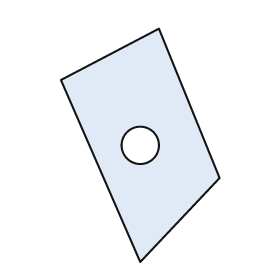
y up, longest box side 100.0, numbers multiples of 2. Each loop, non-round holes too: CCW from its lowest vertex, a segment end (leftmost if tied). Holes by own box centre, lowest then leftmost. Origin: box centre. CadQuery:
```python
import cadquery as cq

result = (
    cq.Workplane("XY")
    .moveTo(0.0, -50.0)
    .lineTo(34.0, -14.0)
    .lineTo(8.0, 50.0)
    .lineTo(-34.0, 28.0)
    .close()
    .moveTo(0.0, 0.0)
    .circle(8.0)
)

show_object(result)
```